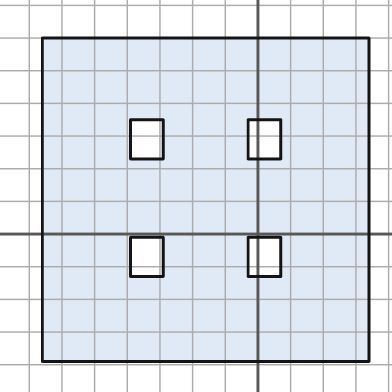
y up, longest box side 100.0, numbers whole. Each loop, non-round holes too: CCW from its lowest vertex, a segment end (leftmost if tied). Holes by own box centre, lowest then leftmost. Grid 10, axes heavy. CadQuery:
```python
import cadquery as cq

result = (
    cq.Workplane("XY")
    .moveTo(-66.0, -39.0)
    .lineTo(34.0, -39.0)
    .lineTo(34.0, 60.0)
    .lineTo(-66.0, 60.0)
    .close()
    .moveTo(-39.0, -13.0)
    .lineTo(-29.0, -13.0)
    .lineTo(-29.0, -1.0)
    .lineTo(-39.0, -1.0)
    .close()
    .moveTo(-3.0, -13.0)
    .lineTo(7.0, -13.0)
    .lineTo(7.0, -1.0)
    .lineTo(-3.0, -1.0)
    .close()
    .moveTo(-39.0, 23.0)
    .lineTo(-29.0, 23.0)
    .lineTo(-29.0, 35.0)
    .lineTo(-39.0, 35.0)
    .close()
    .moveTo(-3.0, 23.0)
    .lineTo(7.0, 23.0)
    .lineTo(7.0, 35.0)
    .lineTo(-3.0, 35.0)
    .close()
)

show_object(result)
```